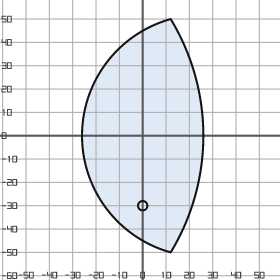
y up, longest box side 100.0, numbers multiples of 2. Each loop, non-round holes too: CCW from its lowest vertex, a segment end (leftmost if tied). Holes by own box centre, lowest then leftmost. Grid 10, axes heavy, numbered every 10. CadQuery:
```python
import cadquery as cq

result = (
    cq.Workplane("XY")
    .moveTo(12.0, -50.0)
    .threePointArc((26.0, 0.0), (12.0, 50.0))
    .threePointArc((-26.0, 0.0), (12.0, -50.0))
    .close()
    .moveTo(0.0, -30.0)
    .circle(2.0)
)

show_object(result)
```